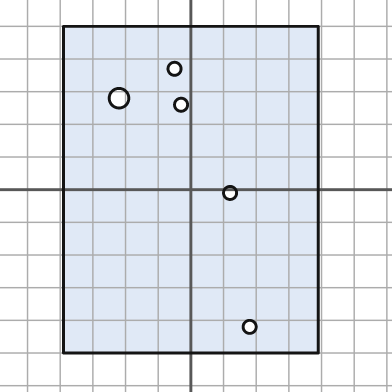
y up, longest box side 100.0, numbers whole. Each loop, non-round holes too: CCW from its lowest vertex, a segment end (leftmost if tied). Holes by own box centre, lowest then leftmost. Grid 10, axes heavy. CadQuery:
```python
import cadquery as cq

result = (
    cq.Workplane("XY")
    .moveTo(-39.0, -50.0)
    .lineTo(39.0, -50.0)
    .lineTo(39.0, 50.0)
    .lineTo(-39.0, 50.0)
    .close()
    .moveTo(18.0, -42.0)
    .circle(2.0)
    .moveTo(12.0, -1.0)
    .circle(2.0)
    .moveTo(-3.0, 26.0)
    .circle(2.0)
    .moveTo(-22.0, 28.0)
    .circle(3.0)
    .moveTo(-5.0, 37.0)
    .circle(2.0)
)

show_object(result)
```